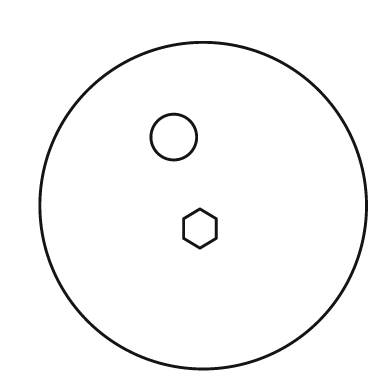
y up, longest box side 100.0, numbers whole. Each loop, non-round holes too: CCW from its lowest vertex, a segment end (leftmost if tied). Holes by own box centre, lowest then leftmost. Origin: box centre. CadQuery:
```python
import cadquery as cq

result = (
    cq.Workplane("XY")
    .moveTo(0.0, 0.0)
    .circle(50.0)
    .moveTo(-1.0, -13.0)
    .lineTo(4.0, -10.0)
    .lineTo(4.0, -4.0)
    .lineTo(-1.0, -1.0)
    .lineTo(-6.0, -4.0)
    .lineTo(-6.0, -10.0)
    .close()
    .moveTo(-9.0, 21.0)
    .circle(7.0)
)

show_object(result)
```